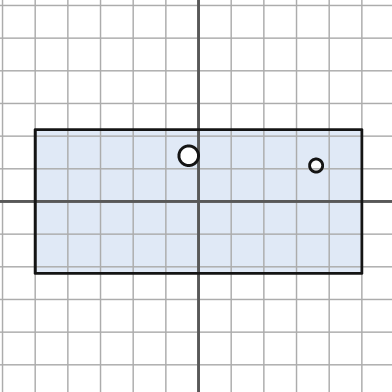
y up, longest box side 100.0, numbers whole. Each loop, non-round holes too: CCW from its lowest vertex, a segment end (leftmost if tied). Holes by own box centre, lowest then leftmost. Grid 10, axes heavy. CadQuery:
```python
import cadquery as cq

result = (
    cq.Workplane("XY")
    .moveTo(-50.0, -22.0)
    .lineTo(50.0, -22.0)
    .lineTo(50.0, 22.0)
    .lineTo(-50.0, 22.0)
    .close()
    .moveTo(36.0, 11.0)
    .circle(2.0)
    .moveTo(-3.0, 14.0)
    .circle(3.0)
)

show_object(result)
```